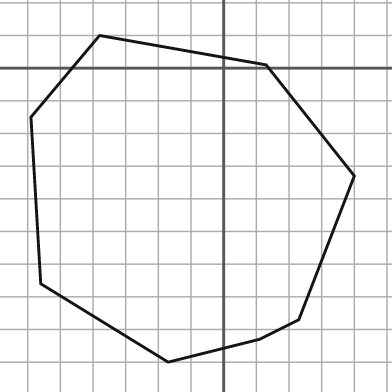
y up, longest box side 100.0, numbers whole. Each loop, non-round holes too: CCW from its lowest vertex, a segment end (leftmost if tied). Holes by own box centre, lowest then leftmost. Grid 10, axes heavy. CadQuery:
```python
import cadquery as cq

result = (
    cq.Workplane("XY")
    .moveTo(-17.0, -90.0)
    .lineTo(11.0, -83.0)
    .lineTo(23.0, -77.0)
    .lineTo(40.0, -33.0)
    .lineTo(13.0, 1.0)
    .lineTo(-38.0, 10.0)
    .lineTo(-59.0, -15.0)
    .lineTo(-56.0, -66.0)
    .close()
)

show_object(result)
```